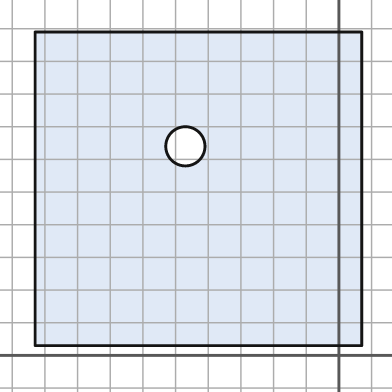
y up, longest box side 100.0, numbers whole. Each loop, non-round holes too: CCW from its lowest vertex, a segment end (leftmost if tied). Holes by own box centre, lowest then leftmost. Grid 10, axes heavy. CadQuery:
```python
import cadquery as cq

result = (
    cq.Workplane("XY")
    .moveTo(-93.0, 3.0)
    .lineTo(7.0, 3.0)
    .lineTo(7.0, 99.0)
    .lineTo(-93.0, 99.0)
    .close()
    .moveTo(-47.0, 64.0)
    .circle(6.0)
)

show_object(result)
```